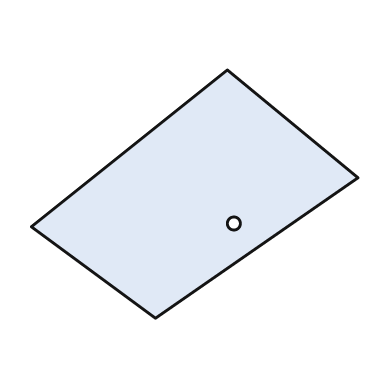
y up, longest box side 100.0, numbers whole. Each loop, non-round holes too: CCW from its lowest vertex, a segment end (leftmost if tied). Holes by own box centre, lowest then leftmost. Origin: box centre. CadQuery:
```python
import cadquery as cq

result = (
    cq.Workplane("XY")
    .moveTo(-12.0, -38.0)
    .lineTo(50.0, 5.0)
    .lineTo(10.0, 38.0)
    .lineTo(-50.0, -10.0)
    .close()
    .moveTo(12.0, -9.0)
    .circle(2.0)
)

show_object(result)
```